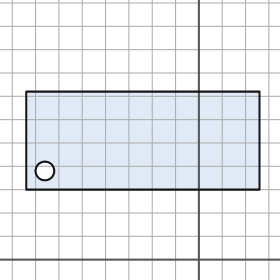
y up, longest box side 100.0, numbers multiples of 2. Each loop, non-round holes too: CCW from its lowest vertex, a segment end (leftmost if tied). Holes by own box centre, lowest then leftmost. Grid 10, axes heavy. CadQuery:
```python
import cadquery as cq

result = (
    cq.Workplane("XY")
    .moveTo(-74.0, 30.0)
    .lineTo(26.0, 30.0)
    .lineTo(26.0, 72.0)
    .lineTo(-74.0, 72.0)
    .close()
    .moveTo(-66.0, 38.0)
    .circle(4.0)
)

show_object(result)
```